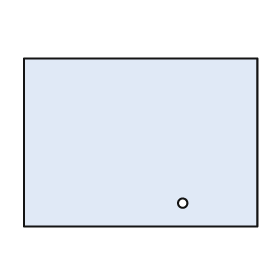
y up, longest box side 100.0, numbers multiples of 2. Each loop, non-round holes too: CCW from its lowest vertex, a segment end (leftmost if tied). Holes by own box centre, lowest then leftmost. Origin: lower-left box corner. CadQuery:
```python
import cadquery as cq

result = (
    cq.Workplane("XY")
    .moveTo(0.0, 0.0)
    .lineTo(100.0, 0.0)
    .lineTo(100.0, 72.0)
    .lineTo(0.0, 72.0)
    .close()
    .moveTo(68.0, 10.0)
    .circle(2.0)
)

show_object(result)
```